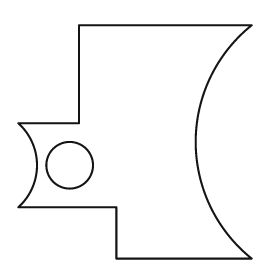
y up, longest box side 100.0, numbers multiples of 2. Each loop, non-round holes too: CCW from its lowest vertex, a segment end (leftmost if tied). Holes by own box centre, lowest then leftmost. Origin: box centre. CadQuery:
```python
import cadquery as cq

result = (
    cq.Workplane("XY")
    .moveTo(-8.0, -50.0)
    .lineTo(50.0, -50.0)
    .threePointArc((26.0, 0.0), (50.0, 50.0))
    .lineTo(-24.0, 50.0)
    .lineTo(-24.0, 8.0)
    .lineTo(-50.0, 8.0)
    .threePointArc((-42.0, -10.0), (-50.0, -28.0))
    .lineTo(-8.0, -28.0)
    .close()
    .moveTo(-28.0, -10.0)
    .circle(10.0)
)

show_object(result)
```